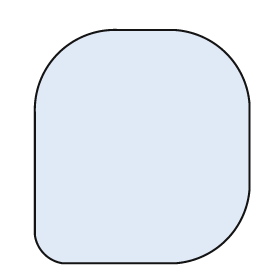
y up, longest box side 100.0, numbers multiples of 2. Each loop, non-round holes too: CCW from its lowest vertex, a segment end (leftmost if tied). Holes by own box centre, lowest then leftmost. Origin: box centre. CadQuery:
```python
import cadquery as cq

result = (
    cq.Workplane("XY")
    .moveTo(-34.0, -50.0)
    .lineTo(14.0, -50.0)
    .threePointArc((36.0, -40.0), (46.0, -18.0))
    .lineTo(46.0, 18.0)
    .threePointArc((36.0, 40.0), (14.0, 50.0))
    .lineTo(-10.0, 50.0)
    .threePointArc((-36.0, 40.0), (-46.0, 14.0))
    .lineTo(-46.0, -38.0)
    .threePointArc((-42.0, -46.0), (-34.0, -50.0))
    .close()
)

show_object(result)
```